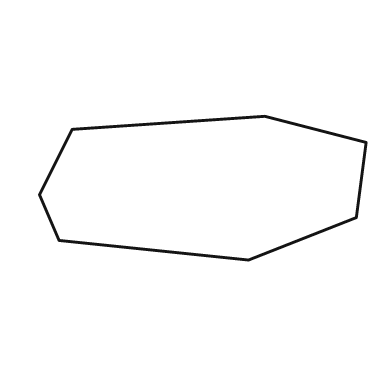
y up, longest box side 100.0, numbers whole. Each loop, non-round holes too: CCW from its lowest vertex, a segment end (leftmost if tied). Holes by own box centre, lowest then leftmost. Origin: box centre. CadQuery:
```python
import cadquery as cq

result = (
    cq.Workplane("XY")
    .moveTo(14.0, -22.0)
    .lineTo(47.0, -9.0)
    .lineTo(50.0, 14.0)
    .lineTo(19.0, 22.0)
    .lineTo(-40.0, 18.0)
    .lineTo(-50.0, -2.0)
    .lineTo(-44.0, -16.0)
    .close()
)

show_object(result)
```